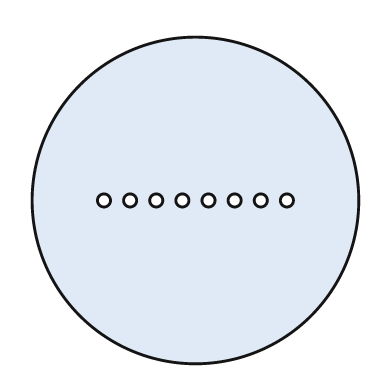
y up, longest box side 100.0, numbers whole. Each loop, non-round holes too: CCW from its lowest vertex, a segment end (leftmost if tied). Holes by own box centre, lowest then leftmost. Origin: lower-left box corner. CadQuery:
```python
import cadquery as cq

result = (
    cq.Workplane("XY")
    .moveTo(50.0, 50.0)
    .circle(50.0)
    .moveTo(22.0, 50.0)
    .circle(2.0)
    .moveTo(30.0, 50.0)
    .circle(2.0)
    .moveTo(38.0, 50.0)
    .circle(2.0)
    .moveTo(46.0, 50.0)
    .circle(2.0)
    .moveTo(54.0, 50.0)
    .circle(2.0)
    .moveTo(62.0, 50.0)
    .circle(2.0)
    .moveTo(70.0, 50.0)
    .circle(2.0)
    .moveTo(78.0, 50.0)
    .circle(2.0)
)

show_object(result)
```